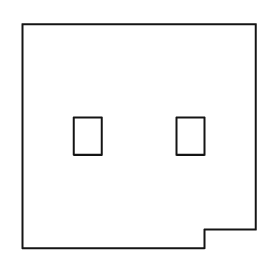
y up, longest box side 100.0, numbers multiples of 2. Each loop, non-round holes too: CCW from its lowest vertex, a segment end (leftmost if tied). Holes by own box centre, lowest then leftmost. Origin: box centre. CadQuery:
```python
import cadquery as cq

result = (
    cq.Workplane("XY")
    .moveTo(-50.0, -48.0)
    .lineTo(28.0, -48.0)
    .lineTo(28.0, -40.0)
    .lineTo(50.0, -40.0)
    .lineTo(50.0, 48.0)
    .lineTo(-50.0, 48.0)
    .close()
    .moveTo(-28.0, -8.0)
    .lineTo(-16.0, -8.0)
    .lineTo(-16.0, 8.0)
    .lineTo(-28.0, 8.0)
    .close()
    .moveTo(16.0, -8.0)
    .lineTo(28.0, -8.0)
    .lineTo(28.0, 8.0)
    .lineTo(16.0, 8.0)
    .close()
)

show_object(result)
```